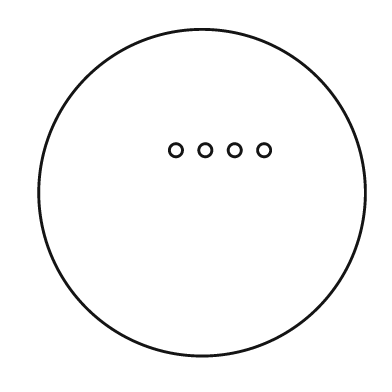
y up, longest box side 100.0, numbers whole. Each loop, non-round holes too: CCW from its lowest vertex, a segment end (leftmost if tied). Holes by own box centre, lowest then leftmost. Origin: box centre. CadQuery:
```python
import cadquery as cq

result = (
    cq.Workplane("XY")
    .moveTo(0.0, 0.0)
    .circle(50.0)
    .moveTo(-8.0, 13.0)
    .circle(2.0)
    .moveTo(1.0, 13.0)
    .circle(2.0)
    .moveTo(10.0, 13.0)
    .circle(2.0)
    .moveTo(19.0, 13.0)
    .circle(2.0)
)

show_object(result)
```